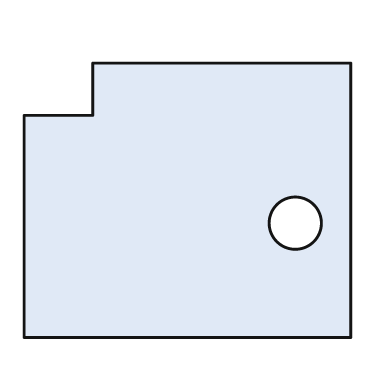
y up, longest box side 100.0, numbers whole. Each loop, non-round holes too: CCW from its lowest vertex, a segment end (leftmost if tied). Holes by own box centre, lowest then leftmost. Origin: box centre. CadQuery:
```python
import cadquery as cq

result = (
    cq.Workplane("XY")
    .moveTo(-50.0, -42.0)
    .lineTo(50.0, -42.0)
    .lineTo(50.0, 42.0)
    .lineTo(-29.0, 42.0)
    .lineTo(-29.0, 26.0)
    .lineTo(-50.0, 26.0)
    .close()
    .moveTo(33.0, -7.0)
    .circle(8.0)
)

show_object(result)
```